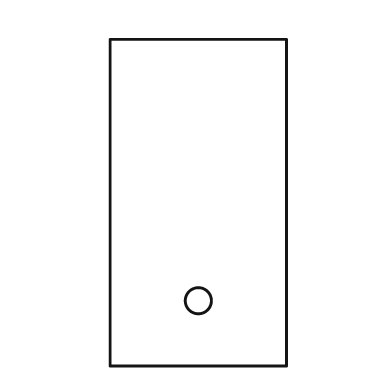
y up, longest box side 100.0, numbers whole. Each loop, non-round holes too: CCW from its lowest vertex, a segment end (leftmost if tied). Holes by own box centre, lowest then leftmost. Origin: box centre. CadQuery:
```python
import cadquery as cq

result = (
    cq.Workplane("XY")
    .moveTo(-27.0, -50.0)
    .lineTo(27.0, -50.0)
    .lineTo(27.0, 50.0)
    .lineTo(-27.0, 50.0)
    .close()
    .moveTo(0.0, -30.0)
    .circle(4.0)
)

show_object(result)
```